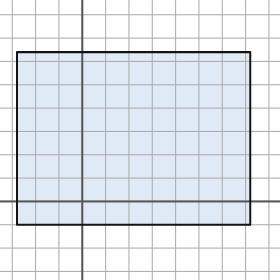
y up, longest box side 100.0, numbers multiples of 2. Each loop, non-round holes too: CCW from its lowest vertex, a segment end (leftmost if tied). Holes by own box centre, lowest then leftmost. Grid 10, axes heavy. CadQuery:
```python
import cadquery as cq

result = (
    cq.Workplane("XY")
    .moveTo(-28.0, -10.0)
    .lineTo(72.0, -10.0)
    .lineTo(72.0, 64.0)
    .lineTo(-28.0, 64.0)
    .close()
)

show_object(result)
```